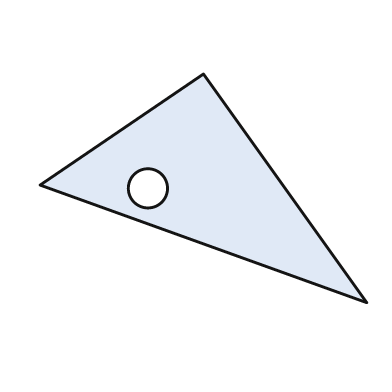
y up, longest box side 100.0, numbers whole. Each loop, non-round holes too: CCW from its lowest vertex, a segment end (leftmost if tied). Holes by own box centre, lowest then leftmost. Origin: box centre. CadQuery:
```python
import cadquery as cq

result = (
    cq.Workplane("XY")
    .moveTo(50.0, -35.0)
    .lineTo(0.0, 35.0)
    .lineTo(-50.0, 1.0)
    .close()
    .moveTo(-17.0, 0.0)
    .circle(6.0)
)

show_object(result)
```